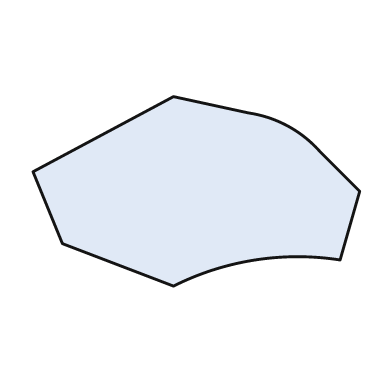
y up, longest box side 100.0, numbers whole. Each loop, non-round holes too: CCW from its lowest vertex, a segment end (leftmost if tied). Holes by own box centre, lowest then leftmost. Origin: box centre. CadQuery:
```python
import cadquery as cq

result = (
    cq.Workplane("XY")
    .moveTo(-7.0, -29.0)
    .threePointArc((18.0, -21.0), (44.0, -21.0))
    .lineTo(50.0, 0.0)
    .lineTo(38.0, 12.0)
    .threePointArc((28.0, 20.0), (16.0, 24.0))
    .lineTo(-7.0, 29.0)
    .lineTo(-50.0, 6.0)
    .lineTo(-41.0, -16.0)
    .close()
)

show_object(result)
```